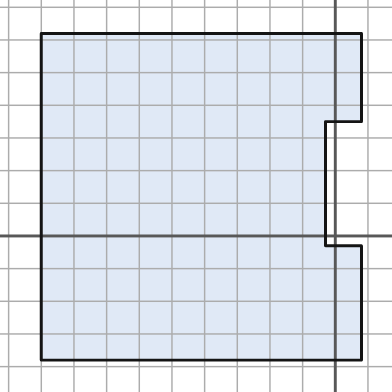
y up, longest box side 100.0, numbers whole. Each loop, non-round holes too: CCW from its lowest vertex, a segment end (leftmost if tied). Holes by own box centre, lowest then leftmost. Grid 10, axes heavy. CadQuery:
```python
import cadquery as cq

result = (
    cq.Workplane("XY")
    .moveTo(-90.0, -38.0)
    .lineTo(8.0, -38.0)
    .lineTo(8.0, -3.0)
    .lineTo(-3.0, -3.0)
    .lineTo(-3.0, 35.0)
    .lineTo(8.0, 35.0)
    .lineTo(8.0, 62.0)
    .lineTo(-90.0, 62.0)
    .close()
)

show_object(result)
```